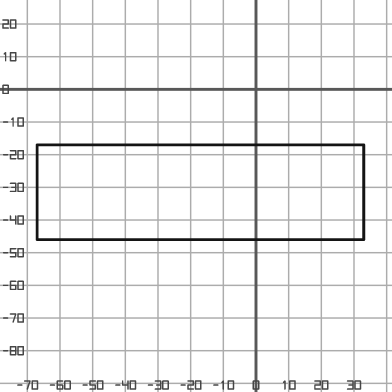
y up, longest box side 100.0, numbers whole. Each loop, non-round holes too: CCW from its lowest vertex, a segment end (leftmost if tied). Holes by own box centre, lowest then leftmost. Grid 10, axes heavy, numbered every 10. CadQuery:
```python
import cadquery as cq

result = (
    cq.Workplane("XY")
    .moveTo(-67.0, -46.0)
    .lineTo(33.0, -46.0)
    .lineTo(33.0, -17.0)
    .lineTo(-67.0, -17.0)
    .close()
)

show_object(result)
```